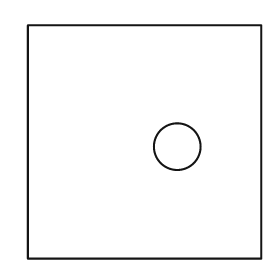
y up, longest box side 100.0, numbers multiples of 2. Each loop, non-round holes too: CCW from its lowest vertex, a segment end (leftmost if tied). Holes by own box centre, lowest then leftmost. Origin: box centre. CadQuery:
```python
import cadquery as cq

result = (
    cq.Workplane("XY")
    .moveTo(-50.0, -50.0)
    .lineTo(50.0, -50.0)
    .lineTo(50.0, 50.0)
    .lineTo(-50.0, 50.0)
    .close()
    .moveTo(14.0, -2.0)
    .circle(10.0)
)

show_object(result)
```